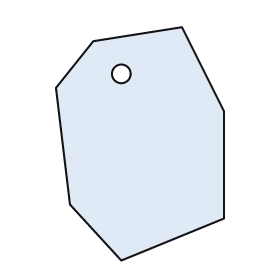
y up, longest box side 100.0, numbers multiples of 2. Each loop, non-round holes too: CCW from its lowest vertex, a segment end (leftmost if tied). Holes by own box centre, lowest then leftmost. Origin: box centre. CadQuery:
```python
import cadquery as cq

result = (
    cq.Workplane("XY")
    .moveTo(-8.0, -50.0)
    .lineTo(36.0, -32.0)
    .lineTo(36.0, 14.0)
    .lineTo(18.0, 50.0)
    .lineTo(-20.0, 44.0)
    .lineTo(-36.0, 24.0)
    .lineTo(-30.0, -26.0)
    .close()
    .moveTo(-8.0, 30.0)
    .circle(4.0)
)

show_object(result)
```